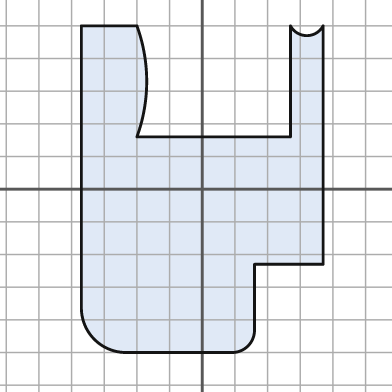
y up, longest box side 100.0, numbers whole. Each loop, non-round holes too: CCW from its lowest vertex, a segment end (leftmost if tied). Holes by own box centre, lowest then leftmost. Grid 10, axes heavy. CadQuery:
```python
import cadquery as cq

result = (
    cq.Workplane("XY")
    .moveTo(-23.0, -50.0)
    .lineTo(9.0, -50.0)
    .threePointArc((14.0, -48.0), (16.0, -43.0))
    .lineTo(16.0, -23.0)
    .lineTo(37.0, -23.0)
    .lineTo(37.0, 50.0)
    .threePointArc((32.0, 47.0), (27.0, 50.0))
    .lineTo(27.0, 16.0)
    .lineTo(-20.0, 16.0)
    .threePointArc((-17.0, 33.0), (-20.0, 50.0))
    .lineTo(-37.0, 50.0)
    .lineTo(-37.0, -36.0)
    .threePointArc((-33.0, -46.0), (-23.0, -50.0))
    .close()
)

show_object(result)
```